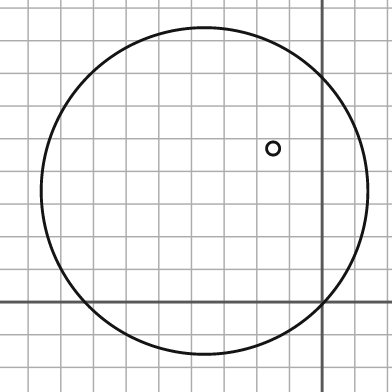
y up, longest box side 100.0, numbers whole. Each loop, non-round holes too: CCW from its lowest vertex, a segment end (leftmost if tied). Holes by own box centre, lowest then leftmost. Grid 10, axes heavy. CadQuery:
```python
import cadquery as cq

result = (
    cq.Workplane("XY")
    .moveTo(-36.0, 34.0)
    .circle(50.0)
    .moveTo(-15.0, 47.0)
    .circle(2.0)
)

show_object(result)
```